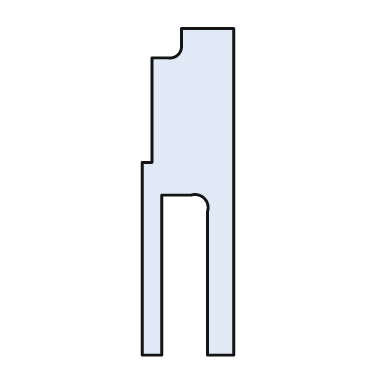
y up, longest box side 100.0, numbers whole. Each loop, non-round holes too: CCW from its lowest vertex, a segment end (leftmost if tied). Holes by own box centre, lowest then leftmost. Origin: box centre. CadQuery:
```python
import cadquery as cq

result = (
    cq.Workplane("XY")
    .moveTo(-14.0, -50.0)
    .lineTo(-8.0, -50.0)
    .lineTo(-8.0, -1.0)
    .lineTo(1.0, -1.0)
    .threePointArc((5.0, -2.0), (6.0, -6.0))
    .lineTo(6.0, -50.0)
    .lineTo(14.0, -50.0)
    .lineTo(14.0, 50.0)
    .lineTo(-2.0, 50.0)
    .lineTo(-2.0, 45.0)
    .threePointArc((-3.0, 42.0), (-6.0, 41.0))
    .lineTo(-11.0, 41.0)
    .lineTo(-11.0, 9.0)
    .lineTo(-14.0, 9.0)
    .close()
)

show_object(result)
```